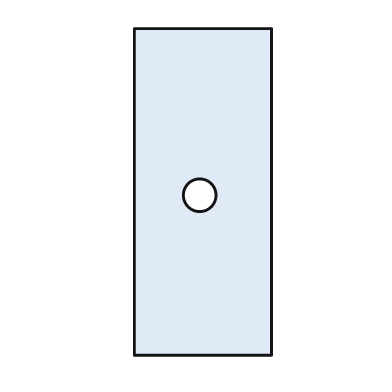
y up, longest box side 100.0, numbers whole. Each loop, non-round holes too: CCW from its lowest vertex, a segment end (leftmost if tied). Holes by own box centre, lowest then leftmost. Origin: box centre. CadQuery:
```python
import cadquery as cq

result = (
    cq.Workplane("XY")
    .moveTo(-21.0, -50.0)
    .lineTo(21.0, -50.0)
    .lineTo(21.0, 50.0)
    .lineTo(-21.0, 50.0)
    .close()
    .moveTo(-1.0, -1.0)
    .circle(5.0)
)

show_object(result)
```